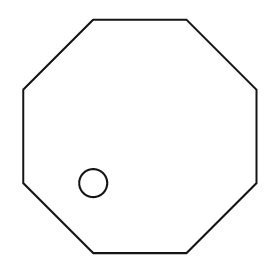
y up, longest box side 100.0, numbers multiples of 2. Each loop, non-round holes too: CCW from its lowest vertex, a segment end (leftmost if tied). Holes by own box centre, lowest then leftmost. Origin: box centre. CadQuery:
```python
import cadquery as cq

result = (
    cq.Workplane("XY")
    .moveTo(-20.0, -50.0)
    .lineTo(20.0, -50.0)
    .lineTo(50.0, -20.0)
    .lineTo(50.0, 20.0)
    .lineTo(20.0, 50.0)
    .lineTo(-20.0, 50.0)
    .lineTo(-50.0, 20.0)
    .lineTo(-50.0, -20.0)
    .close()
    .moveTo(-20.0, -20.0)
    .circle(6.0)
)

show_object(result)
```